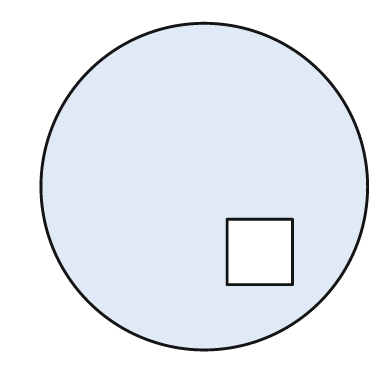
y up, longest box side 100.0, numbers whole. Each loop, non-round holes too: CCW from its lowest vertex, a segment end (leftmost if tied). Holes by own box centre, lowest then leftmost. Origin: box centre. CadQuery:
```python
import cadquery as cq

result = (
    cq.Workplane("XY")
    .moveTo(0.0, 0.0)
    .circle(50.0)
    .moveTo(7.0, -30.0)
    .lineTo(27.0, -30.0)
    .lineTo(27.0, -10.0)
    .lineTo(7.0, -10.0)
    .close()
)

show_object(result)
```